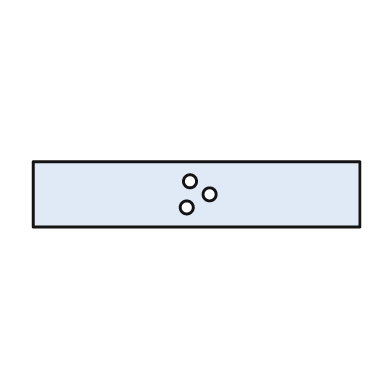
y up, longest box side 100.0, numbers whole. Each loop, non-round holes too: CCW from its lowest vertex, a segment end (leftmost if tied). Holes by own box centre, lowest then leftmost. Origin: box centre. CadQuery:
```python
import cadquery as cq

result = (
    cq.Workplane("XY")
    .moveTo(-50.0, -10.0)
    .lineTo(50.0, -10.0)
    .lineTo(50.0, 10.0)
    .lineTo(-50.0, 10.0)
    .close()
    .moveTo(-3.0, -4.0)
    .circle(2.0)
    .moveTo(4.0, 0.0)
    .circle(2.0)
    .moveTo(-2.0, 4.0)
    .circle(2.0)
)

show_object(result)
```